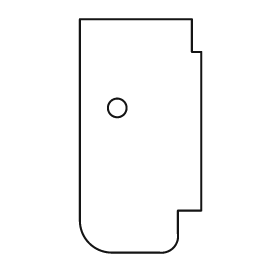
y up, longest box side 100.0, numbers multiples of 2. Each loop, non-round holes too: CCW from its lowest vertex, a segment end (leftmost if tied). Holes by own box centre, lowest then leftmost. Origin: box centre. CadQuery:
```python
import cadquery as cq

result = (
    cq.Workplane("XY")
    .moveTo(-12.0, -50.0)
    .lineTo(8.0, -50.0)
    .threePointArc((14.0, -48.0), (16.0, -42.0))
    .lineTo(16.0, -32.0)
    .lineTo(26.0, -32.0)
    .lineTo(26.0, 36.0)
    .lineTo(22.0, 36.0)
    .lineTo(22.0, 50.0)
    .lineTo(-26.0, 50.0)
    .lineTo(-26.0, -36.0)
    .threePointArc((-22.0, -46.0), (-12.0, -50.0))
    .close()
    .moveTo(-10.0, 12.0)
    .circle(4.0)
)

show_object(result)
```